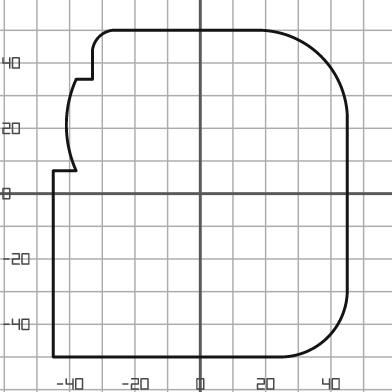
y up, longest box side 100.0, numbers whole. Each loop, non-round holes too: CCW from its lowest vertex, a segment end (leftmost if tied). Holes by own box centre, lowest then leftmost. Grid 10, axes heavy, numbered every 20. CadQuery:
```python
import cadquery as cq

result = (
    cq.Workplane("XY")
    .moveTo(-45.0, -50.0)
    .lineTo(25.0, -50.0)
    .threePointArc((39.0, -44.0), (45.0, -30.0))
    .lineTo(45.0, 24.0)
    .threePointArc((37.0, 42.0), (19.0, 50.0))
    .lineTo(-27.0, 50.0)
    .threePointArc((-31.0, 48.0), (-33.0, 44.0))
    .lineTo(-33.0, 35.0)
    .lineTo(-38.0, 35.0)
    .threePointArc((-41.0, 21.0), (-38.0, 7.0))
    .lineTo(-45.0, 7.0)
    .close()
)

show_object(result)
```